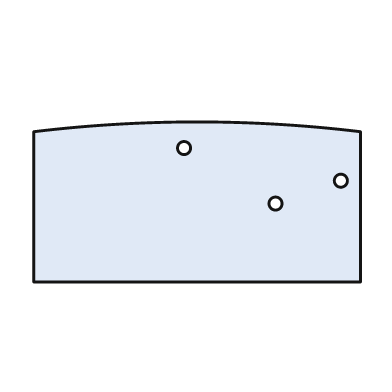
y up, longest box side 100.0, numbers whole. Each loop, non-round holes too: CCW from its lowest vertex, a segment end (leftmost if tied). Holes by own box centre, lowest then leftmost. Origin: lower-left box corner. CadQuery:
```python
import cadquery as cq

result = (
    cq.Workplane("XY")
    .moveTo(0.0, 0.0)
    .lineTo(100.0, 0.0)
    .lineTo(100.0, 46.0)
    .threePointArc((50.0, 49.0), (0.0, 46.0))
    .close()
    .moveTo(74.0, 24.0)
    .circle(2.0)
    .moveTo(94.0, 31.0)
    .circle(2.0)
    .moveTo(46.0, 41.0)
    .circle(2.0)
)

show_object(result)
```